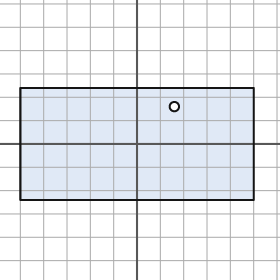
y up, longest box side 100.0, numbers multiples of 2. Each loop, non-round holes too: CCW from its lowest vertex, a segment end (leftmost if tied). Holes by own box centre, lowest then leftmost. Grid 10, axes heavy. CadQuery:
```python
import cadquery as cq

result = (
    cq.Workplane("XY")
    .moveTo(-50.0, -24.0)
    .lineTo(50.0, -24.0)
    .lineTo(50.0, 24.0)
    .lineTo(-50.0, 24.0)
    .close()
    .moveTo(16.0, 16.0)
    .circle(2.0)
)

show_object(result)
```